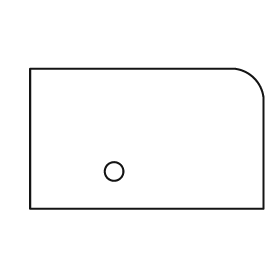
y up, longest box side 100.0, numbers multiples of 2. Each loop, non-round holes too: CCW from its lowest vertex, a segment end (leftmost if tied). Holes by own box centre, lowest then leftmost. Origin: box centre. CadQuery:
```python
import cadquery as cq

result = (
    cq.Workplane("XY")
    .moveTo(-50.0, -30.0)
    .lineTo(50.0, -30.0)
    .lineTo(50.0, 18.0)
    .threePointArc((46.0, 26.0), (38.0, 30.0))
    .lineTo(-50.0, 30.0)
    .close()
    .moveTo(-14.0, -14.0)
    .circle(4.0)
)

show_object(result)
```